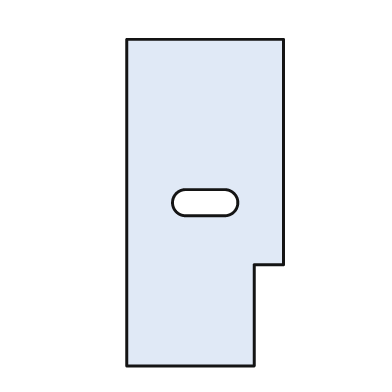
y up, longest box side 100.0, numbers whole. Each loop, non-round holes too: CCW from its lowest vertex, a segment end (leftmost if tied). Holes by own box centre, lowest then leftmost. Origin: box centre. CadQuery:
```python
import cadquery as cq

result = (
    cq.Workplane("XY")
    .moveTo(-24.0, -50.0)
    .lineTo(15.0, -50.0)
    .lineTo(15.0, -19.0)
    .lineTo(24.0, -19.0)
    .lineTo(24.0, 50.0)
    .lineTo(-24.0, 50.0)
    .close()
    .moveTo(-6.0, -4.0)
    .lineTo(6.0, -4.0)
    .threePointArc((10.0, 0.0), (6.0, 4.0))
    .lineTo(-6.0, 4.0)
    .threePointArc((-10.0, 0.0), (-6.0, -4.0))
    .close()
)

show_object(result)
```